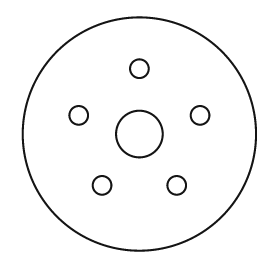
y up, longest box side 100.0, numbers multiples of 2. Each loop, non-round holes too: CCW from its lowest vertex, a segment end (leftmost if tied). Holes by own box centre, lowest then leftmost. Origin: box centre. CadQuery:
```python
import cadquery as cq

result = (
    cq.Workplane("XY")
    .moveTo(0.0, 0.0)
    .circle(50.0)
    .moveTo(-16.0, -22.0)
    .circle(4.0)
    .moveTo(16.0, -22.0)
    .circle(4.0)
    .moveTo(0.0, 0.0)
    .circle(10.0)
    .moveTo(-26.0, 8.0)
    .circle(4.0)
    .moveTo(26.0, 8.0)
    .circle(4.0)
    .moveTo(0.0, 28.0)
    .circle(4.0)
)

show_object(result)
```